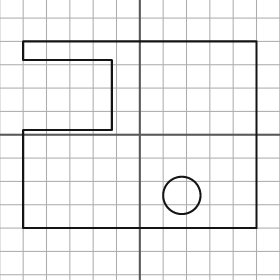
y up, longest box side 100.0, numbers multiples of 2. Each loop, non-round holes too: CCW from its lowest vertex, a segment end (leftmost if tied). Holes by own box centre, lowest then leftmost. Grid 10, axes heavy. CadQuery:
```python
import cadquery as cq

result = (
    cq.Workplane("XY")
    .moveTo(-50.0, -40.0)
    .lineTo(50.0, -40.0)
    .lineTo(50.0, 40.0)
    .lineTo(-50.0, 40.0)
    .lineTo(-50.0, 32.0)
    .lineTo(-12.0, 32.0)
    .lineTo(-12.0, 2.0)
    .lineTo(-50.0, 2.0)
    .close()
    .moveTo(18.0, -26.0)
    .circle(8.0)
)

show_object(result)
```